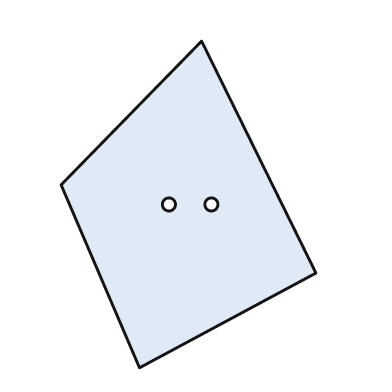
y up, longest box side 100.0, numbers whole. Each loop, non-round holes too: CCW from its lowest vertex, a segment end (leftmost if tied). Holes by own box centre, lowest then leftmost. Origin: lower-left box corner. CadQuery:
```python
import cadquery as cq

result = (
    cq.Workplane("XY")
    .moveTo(24.0, 0.0)
    .lineTo(78.0, 29.0)
    .lineTo(43.0, 100.0)
    .lineTo(0.0, 56.0)
    .close()
    .moveTo(33.0, 50.0)
    .circle(2.0)
    .moveTo(46.0, 50.0)
    .circle(2.0)
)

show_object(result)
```